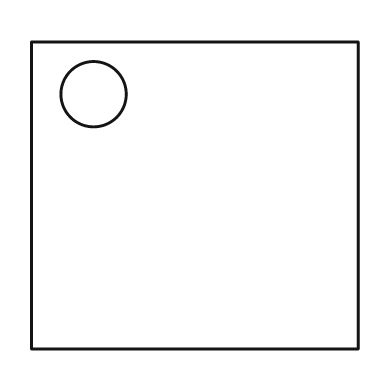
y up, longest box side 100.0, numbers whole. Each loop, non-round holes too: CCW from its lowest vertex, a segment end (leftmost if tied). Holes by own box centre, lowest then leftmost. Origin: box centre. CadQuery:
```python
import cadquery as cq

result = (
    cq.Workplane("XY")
    .moveTo(-50.0, -47.0)
    .lineTo(50.0, -47.0)
    .lineTo(50.0, 47.0)
    .lineTo(-50.0, 47.0)
    .close()
    .moveTo(-31.0, 31.0)
    .circle(10.0)
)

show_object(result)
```